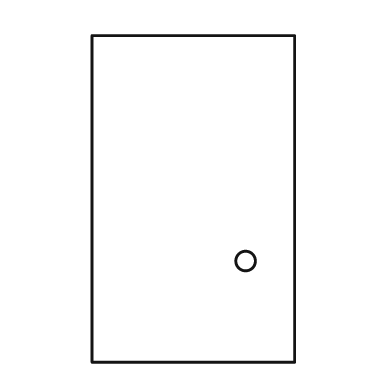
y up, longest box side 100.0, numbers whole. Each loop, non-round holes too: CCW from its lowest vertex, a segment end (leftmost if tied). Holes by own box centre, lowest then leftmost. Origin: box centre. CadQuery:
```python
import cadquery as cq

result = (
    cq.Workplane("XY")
    .moveTo(-31.0, -50.0)
    .lineTo(31.0, -50.0)
    .lineTo(31.0, 50.0)
    .lineTo(-31.0, 50.0)
    .close()
    .moveTo(16.0, -19.0)
    .circle(3.0)
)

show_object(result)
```